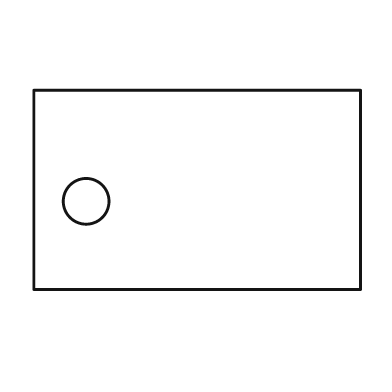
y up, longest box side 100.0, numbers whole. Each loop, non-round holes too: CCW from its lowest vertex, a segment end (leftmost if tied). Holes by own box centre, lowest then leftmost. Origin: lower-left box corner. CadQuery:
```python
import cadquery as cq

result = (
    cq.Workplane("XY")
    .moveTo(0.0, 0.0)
    .lineTo(100.0, 0.0)
    .lineTo(100.0, 61.0)
    .lineTo(0.0, 61.0)
    .close()
    .moveTo(16.0, 27.0)
    .circle(7.0)
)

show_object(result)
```